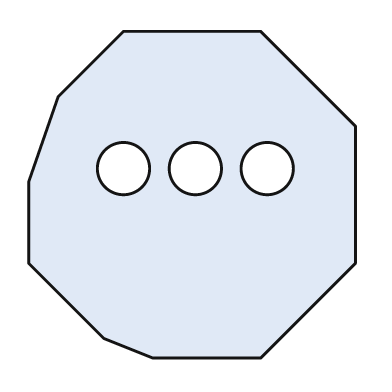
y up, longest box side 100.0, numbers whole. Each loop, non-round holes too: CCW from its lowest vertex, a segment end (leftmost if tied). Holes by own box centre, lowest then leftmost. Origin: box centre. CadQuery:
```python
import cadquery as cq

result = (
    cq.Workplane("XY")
    .moveTo(-12.0, -50.0)
    .lineTo(21.0, -50.0)
    .lineTo(50.0, -21.0)
    .lineTo(50.0, 21.0)
    .lineTo(21.0, 50.0)
    .lineTo(-21.0, 50.0)
    .lineTo(-41.0, 30.0)
    .lineTo(-50.0, 4.0)
    .lineTo(-50.0, -21.0)
    .lineTo(-27.0, -44.0)
    .close()
    .moveTo(-21.0, 8.0)
    .circle(8.0)
    .moveTo(1.0, 8.0)
    .circle(8.0)
    .moveTo(23.0, 8.0)
    .circle(8.0)
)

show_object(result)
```